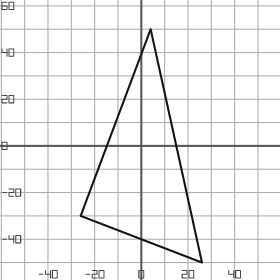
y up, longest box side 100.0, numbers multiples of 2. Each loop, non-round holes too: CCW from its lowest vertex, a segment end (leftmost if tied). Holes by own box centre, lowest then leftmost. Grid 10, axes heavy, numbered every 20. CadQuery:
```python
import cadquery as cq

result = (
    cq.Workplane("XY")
    .moveTo(26.0, -50.0)
    .lineTo(4.0, 50.0)
    .lineTo(-26.0, -30.0)
    .close()
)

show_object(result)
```